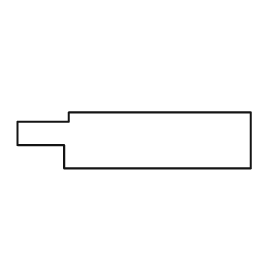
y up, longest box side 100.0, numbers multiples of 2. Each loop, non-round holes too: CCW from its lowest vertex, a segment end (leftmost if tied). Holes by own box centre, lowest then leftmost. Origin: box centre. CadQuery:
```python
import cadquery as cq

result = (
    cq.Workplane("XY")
    .moveTo(-30.0, -12.0)
    .lineTo(50.0, -12.0)
    .lineTo(50.0, 12.0)
    .lineTo(-28.0, 12.0)
    .lineTo(-28.0, 8.0)
    .lineTo(-50.0, 8.0)
    .lineTo(-50.0, -2.0)
    .lineTo(-30.0, -2.0)
    .close()
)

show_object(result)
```